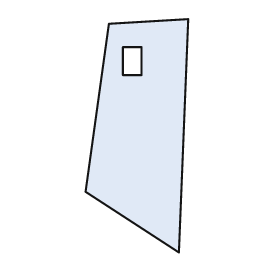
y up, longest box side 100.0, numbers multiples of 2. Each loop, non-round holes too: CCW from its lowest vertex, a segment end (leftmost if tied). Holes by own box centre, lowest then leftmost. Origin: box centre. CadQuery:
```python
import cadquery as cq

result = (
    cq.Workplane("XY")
    .moveTo(18.0, -50.0)
    .lineTo(22.0, 50.0)
    .lineTo(-12.0, 48.0)
    .lineTo(-22.0, -24.0)
    .close()
    .moveTo(-6.0, 26.0)
    .lineTo(2.0, 26.0)
    .lineTo(2.0, 38.0)
    .lineTo(-6.0, 38.0)
    .close()
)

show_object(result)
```